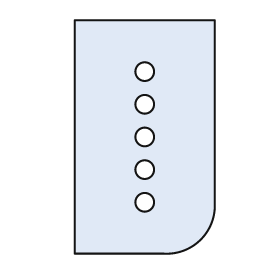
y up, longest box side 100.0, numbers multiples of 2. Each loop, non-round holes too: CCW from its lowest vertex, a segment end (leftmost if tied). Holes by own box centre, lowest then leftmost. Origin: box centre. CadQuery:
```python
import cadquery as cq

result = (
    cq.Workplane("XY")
    .moveTo(-30.0, -50.0)
    .lineTo(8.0, -50.0)
    .threePointArc((24.0, -44.0), (30.0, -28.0))
    .lineTo(30.0, 50.0)
    .lineTo(-30.0, 50.0)
    .close()
    .moveTo(0.0, -28.0)
    .circle(4.0)
    .moveTo(0.0, -14.0)
    .circle(4.0)
    .moveTo(0.0, 0.0)
    .circle(4.0)
    .moveTo(0.0, 14.0)
    .circle(4.0)
    .moveTo(0.0, 28.0)
    .circle(4.0)
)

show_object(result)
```